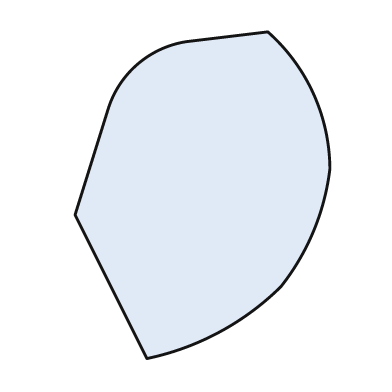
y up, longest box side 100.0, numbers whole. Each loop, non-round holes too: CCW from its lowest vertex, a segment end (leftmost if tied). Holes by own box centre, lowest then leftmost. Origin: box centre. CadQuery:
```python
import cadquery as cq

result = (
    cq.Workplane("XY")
    .moveTo(-17.0, -50.0)
    .threePointArc((5.0, -42.0), (24.0, -28.0))
    .threePointArc((34.0, -11.0), (39.0, 8.0))
    .threePointArc((34.0, 31.0), (20.0, 50.0))
    .lineTo(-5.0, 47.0)
    .threePointArc((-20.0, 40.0), (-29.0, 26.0))
    .lineTo(-39.0, -6.0)
    .close()
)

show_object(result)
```